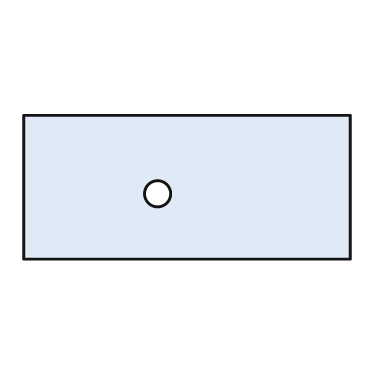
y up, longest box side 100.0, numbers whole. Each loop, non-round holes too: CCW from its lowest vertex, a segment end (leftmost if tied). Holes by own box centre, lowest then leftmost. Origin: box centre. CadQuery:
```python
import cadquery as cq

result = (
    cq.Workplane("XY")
    .moveTo(-50.0, -22.0)
    .lineTo(50.0, -22.0)
    .lineTo(50.0, 22.0)
    .lineTo(-50.0, 22.0)
    .close()
    .moveTo(-9.0, -2.0)
    .circle(4.0)
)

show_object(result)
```